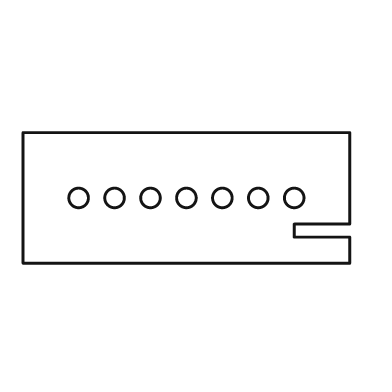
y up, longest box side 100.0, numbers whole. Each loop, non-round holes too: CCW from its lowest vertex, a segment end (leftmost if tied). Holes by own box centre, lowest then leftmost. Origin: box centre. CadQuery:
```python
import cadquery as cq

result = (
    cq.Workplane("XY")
    .moveTo(-50.0, -20.0)
    .lineTo(50.0, -20.0)
    .lineTo(50.0, -12.0)
    .lineTo(33.0, -12.0)
    .lineTo(33.0, -8.0)
    .lineTo(50.0, -8.0)
    .lineTo(50.0, 20.0)
    .lineTo(-50.0, 20.0)
    .close()
    .moveTo(-33.0, 0.0)
    .circle(3.0)
    .moveTo(-22.0, 0.0)
    .circle(3.0)
    .moveTo(-11.0, 0.0)
    .circle(3.0)
    .moveTo(0.0, 0.0)
    .circle(3.0)
    .moveTo(11.0, 0.0)
    .circle(3.0)
    .moveTo(22.0, 0.0)
    .circle(3.0)
    .moveTo(33.0, 0.0)
    .circle(3.0)
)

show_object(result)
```